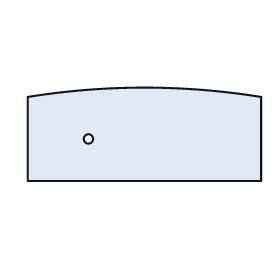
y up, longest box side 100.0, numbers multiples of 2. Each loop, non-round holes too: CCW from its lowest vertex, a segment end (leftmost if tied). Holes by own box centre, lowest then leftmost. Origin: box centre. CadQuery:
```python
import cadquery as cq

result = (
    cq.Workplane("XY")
    .moveTo(-50.0, -20.0)
    .lineTo(50.0, -20.0)
    .lineTo(50.0, 16.0)
    .threePointArc((0.0, 20.0), (-50.0, 16.0))
    .close()
    .moveTo(-24.0, -2.0)
    .circle(2.0)
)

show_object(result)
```